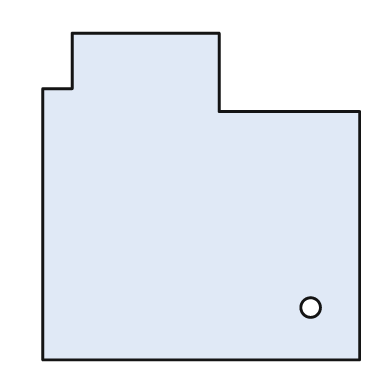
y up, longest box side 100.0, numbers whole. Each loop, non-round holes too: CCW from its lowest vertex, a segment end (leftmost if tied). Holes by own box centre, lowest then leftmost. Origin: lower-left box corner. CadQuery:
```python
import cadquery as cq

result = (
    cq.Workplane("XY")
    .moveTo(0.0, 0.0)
    .lineTo(97.0, 0.0)
    .lineTo(97.0, 76.0)
    .lineTo(54.0, 76.0)
    .lineTo(54.0, 100.0)
    .lineTo(9.0, 100.0)
    .lineTo(9.0, 83.0)
    .lineTo(0.0, 83.0)
    .close()
    .moveTo(82.0, 16.0)
    .circle(3.0)
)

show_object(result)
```